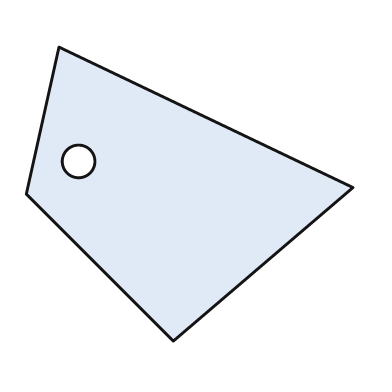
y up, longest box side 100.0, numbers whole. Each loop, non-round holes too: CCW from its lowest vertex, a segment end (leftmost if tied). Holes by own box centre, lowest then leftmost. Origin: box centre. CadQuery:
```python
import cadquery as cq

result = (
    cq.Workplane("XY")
    .moveTo(-5.0, -45.0)
    .lineTo(50.0, 2.0)
    .lineTo(-40.0, 45.0)
    .lineTo(-50.0, 0.0)
    .close()
    .moveTo(-34.0, 10.0)
    .circle(5.0)
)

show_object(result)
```